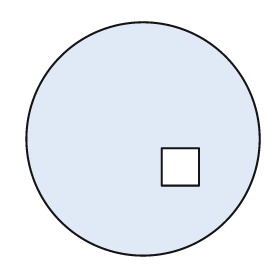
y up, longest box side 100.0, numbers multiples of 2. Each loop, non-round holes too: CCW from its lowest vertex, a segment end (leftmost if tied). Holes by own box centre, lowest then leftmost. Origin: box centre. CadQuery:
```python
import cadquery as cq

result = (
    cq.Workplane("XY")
    .moveTo(0.0, 0.0)
    .circle(50.0)
    .moveTo(8.0, -20.0)
    .lineTo(24.0, -20.0)
    .lineTo(24.0, -4.0)
    .lineTo(8.0, -4.0)
    .close()
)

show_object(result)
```